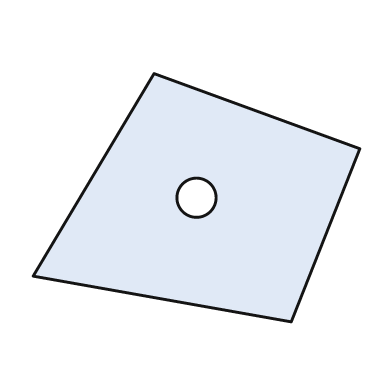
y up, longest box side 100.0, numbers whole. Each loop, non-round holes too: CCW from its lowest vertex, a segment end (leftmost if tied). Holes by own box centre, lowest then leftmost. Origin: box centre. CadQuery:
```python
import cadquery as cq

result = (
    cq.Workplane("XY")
    .moveTo(29.0, -38.0)
    .lineTo(50.0, 15.0)
    .lineTo(-13.0, 38.0)
    .lineTo(-50.0, -24.0)
    .close()
    .moveTo(0.0, 0.0)
    .circle(6.0)
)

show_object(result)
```